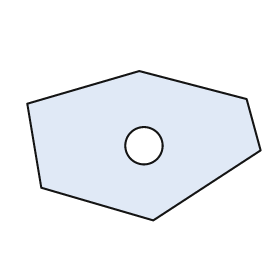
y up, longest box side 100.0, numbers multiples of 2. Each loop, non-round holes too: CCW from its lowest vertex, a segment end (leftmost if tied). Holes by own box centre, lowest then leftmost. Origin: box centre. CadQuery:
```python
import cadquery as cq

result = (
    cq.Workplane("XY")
    .moveTo(4.0, -32.0)
    .lineTo(50.0, -2.0)
    .lineTo(44.0, 20.0)
    .lineTo(-2.0, 32.0)
    .lineTo(-50.0, 18.0)
    .lineTo(-44.0, -18.0)
    .close()
    .moveTo(0.0, 0.0)
    .circle(8.0)
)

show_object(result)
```